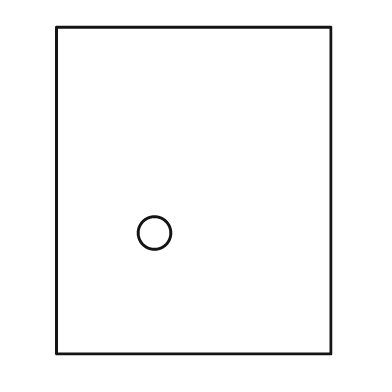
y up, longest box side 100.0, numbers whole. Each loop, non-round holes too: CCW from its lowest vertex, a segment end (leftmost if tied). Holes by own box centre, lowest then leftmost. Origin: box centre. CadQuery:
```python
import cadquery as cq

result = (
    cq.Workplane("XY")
    .moveTo(-42.0, -50.0)
    .lineTo(42.0, -50.0)
    .lineTo(42.0, 50.0)
    .lineTo(-42.0, 50.0)
    .close()
    .moveTo(-12.0, -13.0)
    .circle(5.0)
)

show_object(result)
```